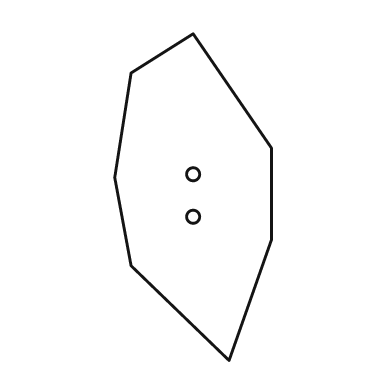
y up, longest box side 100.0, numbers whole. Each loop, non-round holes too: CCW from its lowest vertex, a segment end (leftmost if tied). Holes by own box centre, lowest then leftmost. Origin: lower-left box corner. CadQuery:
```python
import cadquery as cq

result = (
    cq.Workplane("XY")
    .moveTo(35.0, 0.0)
    .lineTo(48.0, 37.0)
    .lineTo(48.0, 65.0)
    .lineTo(24.0, 100.0)
    .lineTo(5.0, 88.0)
    .lineTo(0.0, 56.0)
    .lineTo(5.0, 29.0)
    .close()
    .moveTo(24.0, 44.0)
    .circle(2.0)
    .moveTo(24.0, 57.0)
    .circle(2.0)
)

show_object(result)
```